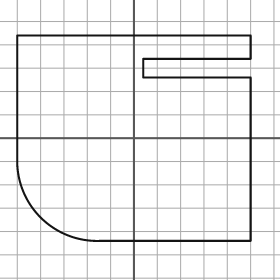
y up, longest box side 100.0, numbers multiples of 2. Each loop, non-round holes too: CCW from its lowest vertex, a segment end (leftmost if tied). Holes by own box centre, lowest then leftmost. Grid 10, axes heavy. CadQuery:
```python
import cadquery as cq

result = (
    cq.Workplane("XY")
    .moveTo(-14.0, -44.0)
    .lineTo(50.0, -44.0)
    .lineTo(50.0, 26.0)
    .lineTo(4.0, 26.0)
    .lineTo(4.0, 34.0)
    .lineTo(50.0, 34.0)
    .lineTo(50.0, 44.0)
    .lineTo(-50.0, 44.0)
    .lineTo(-50.0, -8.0)
    .threePointArc((-40.0, -34.0), (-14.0, -44.0))
    .close()
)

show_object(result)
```